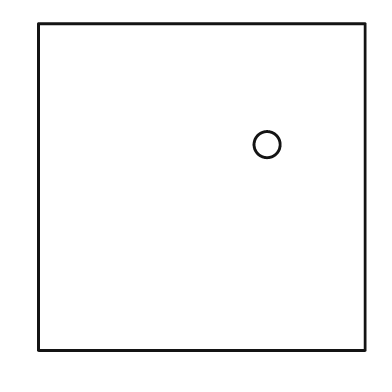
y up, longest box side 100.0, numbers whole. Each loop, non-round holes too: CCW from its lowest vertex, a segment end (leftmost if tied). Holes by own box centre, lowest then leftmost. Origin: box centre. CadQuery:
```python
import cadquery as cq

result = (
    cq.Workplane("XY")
    .moveTo(-50.0, -50.0)
    .lineTo(50.0, -50.0)
    .lineTo(50.0, 50.0)
    .lineTo(-50.0, 50.0)
    .close()
    .moveTo(20.0, 13.0)
    .circle(4.0)
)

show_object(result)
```